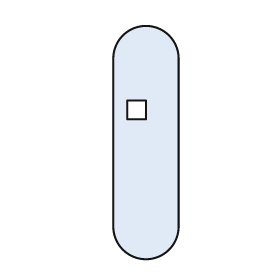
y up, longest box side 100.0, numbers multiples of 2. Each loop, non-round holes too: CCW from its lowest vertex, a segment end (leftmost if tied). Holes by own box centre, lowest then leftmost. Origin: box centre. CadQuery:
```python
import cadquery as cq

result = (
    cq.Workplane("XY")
    .moveTo(-14.0, -36.0)
    .threePointArc((0.0, -50.0), (14.0, -36.0))
    .lineTo(14.0, 36.0)
    .threePointArc((0.0, 50.0), (-14.0, 36.0))
    .close()
    .moveTo(-8.0, 10.0)
    .lineTo(0.0, 10.0)
    .lineTo(0.0, 18.0)
    .lineTo(-8.0, 18.0)
    .close()
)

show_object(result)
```